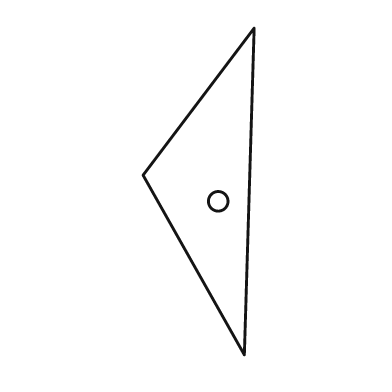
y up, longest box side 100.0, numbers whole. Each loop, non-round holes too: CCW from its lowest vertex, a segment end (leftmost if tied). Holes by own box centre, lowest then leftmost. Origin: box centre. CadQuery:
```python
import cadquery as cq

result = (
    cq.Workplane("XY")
    .moveTo(14.0, -50.0)
    .lineTo(17.0, 50.0)
    .lineTo(-17.0, 5.0)
    .close()
    .moveTo(6.0, -3.0)
    .circle(3.0)
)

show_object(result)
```